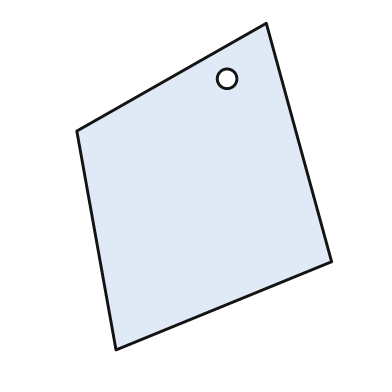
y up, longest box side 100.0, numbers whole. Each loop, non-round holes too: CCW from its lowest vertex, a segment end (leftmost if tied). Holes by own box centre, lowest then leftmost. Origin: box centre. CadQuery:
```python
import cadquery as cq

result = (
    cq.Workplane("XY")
    .moveTo(-27.0, -50.0)
    .lineTo(39.0, -23.0)
    .lineTo(19.0, 50.0)
    .lineTo(-39.0, 17.0)
    .close()
    .moveTo(7.0, 33.0)
    .circle(3.0)
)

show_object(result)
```